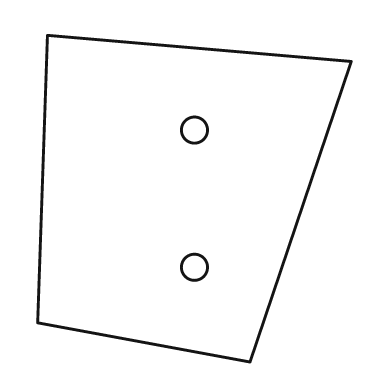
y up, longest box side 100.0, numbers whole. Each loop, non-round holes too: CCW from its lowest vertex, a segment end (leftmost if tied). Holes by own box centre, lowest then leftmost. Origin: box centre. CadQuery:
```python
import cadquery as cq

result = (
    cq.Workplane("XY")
    .moveTo(17.0, -50.0)
    .lineTo(48.0, 42.0)
    .lineTo(-45.0, 50.0)
    .lineTo(-48.0, -38.0)
    .close()
    .moveTo(0.0, -21.0)
    .circle(4.0)
    .moveTo(0.0, 21.0)
    .circle(4.0)
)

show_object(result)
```